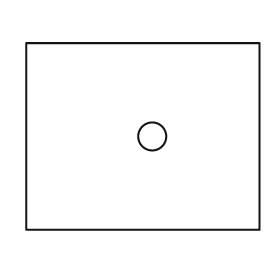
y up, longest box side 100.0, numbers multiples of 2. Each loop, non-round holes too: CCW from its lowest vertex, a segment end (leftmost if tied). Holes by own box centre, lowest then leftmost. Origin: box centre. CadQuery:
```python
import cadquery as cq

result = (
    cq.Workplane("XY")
    .moveTo(-50.0, -40.0)
    .lineTo(50.0, -40.0)
    .lineTo(50.0, 40.0)
    .lineTo(-50.0, 40.0)
    .close()
    .moveTo(4.0, 0.0)
    .circle(6.0)
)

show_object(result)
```